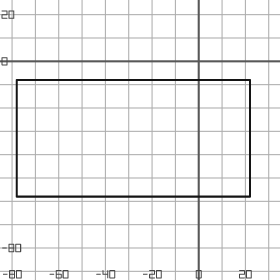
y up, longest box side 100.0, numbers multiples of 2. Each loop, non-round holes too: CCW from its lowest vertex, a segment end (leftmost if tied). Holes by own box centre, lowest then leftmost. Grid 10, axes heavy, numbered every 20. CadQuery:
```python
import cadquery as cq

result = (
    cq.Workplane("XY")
    .moveTo(-78.0, -58.0)
    .lineTo(22.0, -58.0)
    .lineTo(22.0, -8.0)
    .lineTo(-78.0, -8.0)
    .close()
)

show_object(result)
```